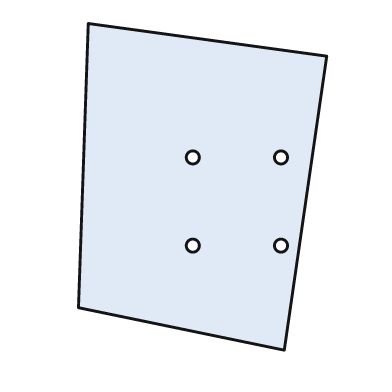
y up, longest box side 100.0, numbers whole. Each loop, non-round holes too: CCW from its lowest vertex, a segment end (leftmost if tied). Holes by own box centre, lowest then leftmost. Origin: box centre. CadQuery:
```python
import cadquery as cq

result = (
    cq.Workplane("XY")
    .moveTo(25.0, -50.0)
    .lineTo(38.0, 40.0)
    .lineTo(-35.0, 50.0)
    .lineTo(-38.0, -37.0)
    .close()
    .moveTo(-3.0, -18.0)
    .circle(2.0)
    .moveTo(24.0, -18.0)
    .circle(2.0)
    .moveTo(-3.0, 9.0)
    .circle(2.0)
    .moveTo(24.0, 9.0)
    .circle(2.0)
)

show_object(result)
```